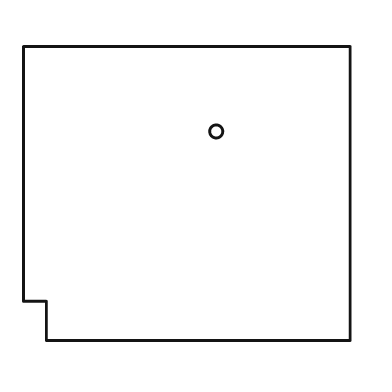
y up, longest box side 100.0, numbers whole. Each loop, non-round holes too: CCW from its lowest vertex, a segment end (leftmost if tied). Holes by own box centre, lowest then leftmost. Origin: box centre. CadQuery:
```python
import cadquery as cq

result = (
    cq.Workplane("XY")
    .moveTo(-43.0, -45.0)
    .lineTo(50.0, -45.0)
    .lineTo(50.0, 45.0)
    .lineTo(-50.0, 45.0)
    .lineTo(-50.0, -33.0)
    .lineTo(-43.0, -33.0)
    .close()
    .moveTo(9.0, 19.0)
    .circle(2.0)
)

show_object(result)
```